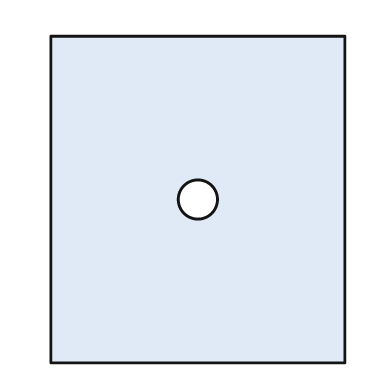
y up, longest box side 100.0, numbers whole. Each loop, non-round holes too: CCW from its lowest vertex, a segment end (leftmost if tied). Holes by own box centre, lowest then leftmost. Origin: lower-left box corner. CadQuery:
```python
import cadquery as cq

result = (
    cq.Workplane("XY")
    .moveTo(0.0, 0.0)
    .lineTo(90.0, 0.0)
    .lineTo(90.0, 100.0)
    .lineTo(0.0, 100.0)
    .close()
    .moveTo(45.0, 50.0)
    .circle(6.0)
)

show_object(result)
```